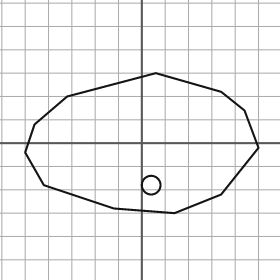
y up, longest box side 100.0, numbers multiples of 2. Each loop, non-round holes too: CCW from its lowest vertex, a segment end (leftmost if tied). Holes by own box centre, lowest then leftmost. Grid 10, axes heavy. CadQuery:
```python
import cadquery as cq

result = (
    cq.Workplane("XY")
    .moveTo(14.0, -30.0)
    .lineTo(34.0, -22.0)
    .lineTo(50.0, -2.0)
    .lineTo(44.0, 14.0)
    .lineTo(34.0, 22.0)
    .lineTo(6.0, 30.0)
    .lineTo(-32.0, 20.0)
    .lineTo(-46.0, 8.0)
    .lineTo(-50.0, -4.0)
    .lineTo(-42.0, -18.0)
    .lineTo(-12.0, -28.0)
    .close()
    .moveTo(4.0, -18.0)
    .circle(4.0)
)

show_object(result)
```